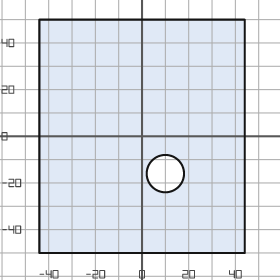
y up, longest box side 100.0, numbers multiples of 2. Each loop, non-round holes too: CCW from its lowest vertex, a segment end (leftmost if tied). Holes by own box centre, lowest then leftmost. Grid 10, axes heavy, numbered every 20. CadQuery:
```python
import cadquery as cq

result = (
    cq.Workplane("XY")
    .moveTo(-44.0, -50.0)
    .lineTo(44.0, -50.0)
    .lineTo(44.0, 50.0)
    .lineTo(-44.0, 50.0)
    .close()
    .moveTo(10.0, -16.0)
    .circle(8.0)
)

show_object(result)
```